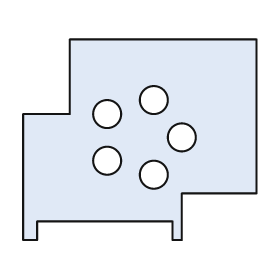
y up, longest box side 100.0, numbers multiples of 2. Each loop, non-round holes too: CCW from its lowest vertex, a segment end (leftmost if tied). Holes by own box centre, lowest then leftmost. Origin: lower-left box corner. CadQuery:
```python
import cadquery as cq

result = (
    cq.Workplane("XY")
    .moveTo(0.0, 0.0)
    .lineTo(6.0, 0.0)
    .lineTo(6.0, 8.0)
    .lineTo(64.0, 8.0)
    .lineTo(64.0, 0.0)
    .lineTo(68.0, 0.0)
    .lineTo(68.0, 20.0)
    .lineTo(100.0, 20.0)
    .lineTo(100.0, 86.0)
    .lineTo(20.0, 86.0)
    .lineTo(20.0, 54.0)
    .lineTo(0.0, 54.0)
    .close()
    .moveTo(56.0, 28.0)
    .circle(6.0)
    .moveTo(36.0, 34.0)
    .circle(6.0)
    .moveTo(68.0, 44.0)
    .circle(6.0)
    .moveTo(36.0, 54.0)
    .circle(6.0)
    .moveTo(56.0, 60.0)
    .circle(6.0)
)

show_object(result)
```